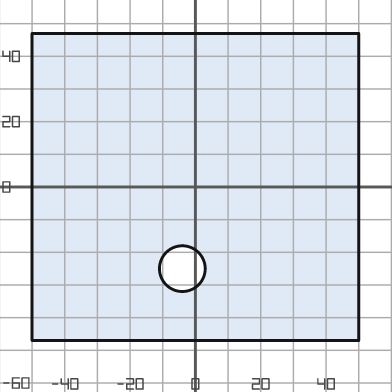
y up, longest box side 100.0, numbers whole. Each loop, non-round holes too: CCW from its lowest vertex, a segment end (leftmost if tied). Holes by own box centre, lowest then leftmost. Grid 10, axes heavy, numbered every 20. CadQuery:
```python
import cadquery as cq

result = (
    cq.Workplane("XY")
    .moveTo(-50.0, -47.0)
    .lineTo(50.0, -47.0)
    .lineTo(50.0, 47.0)
    .lineTo(-50.0, 47.0)
    .close()
    .moveTo(-4.0, -25.0)
    .circle(7.0)
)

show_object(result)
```